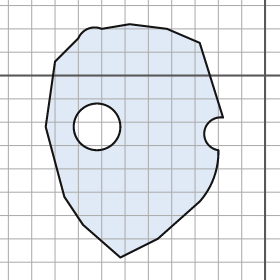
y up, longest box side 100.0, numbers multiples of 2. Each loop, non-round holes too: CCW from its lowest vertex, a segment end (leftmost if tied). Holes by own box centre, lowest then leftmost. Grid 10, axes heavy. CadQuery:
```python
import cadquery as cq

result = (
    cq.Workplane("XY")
    .moveTo(-62.0, -78.0)
    .lineTo(-46.0, -70.0)
    .lineTo(-28.0, -54.0)
    .threePointArc((-22.0, -44.0), (-20.0, -32.0))
    .threePointArc((-26.0, -24.0), (-18.0, -18.0))
    .lineTo(-28.0, 14.0)
    .lineTo(-42.0, 20.0)
    .lineTo(-58.0, 22.0)
    .lineTo(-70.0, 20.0)
    .threePointArc((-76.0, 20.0), (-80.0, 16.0))
    .lineTo(-90.0, 6.0)
    .lineTo(-94.0, -22.0)
    .lineTo(-86.0, -52.0)
    .lineTo(-78.0, -64.0)
    .close()
    .moveTo(-72.0, -22.0)
    .circle(10.0)
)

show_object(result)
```